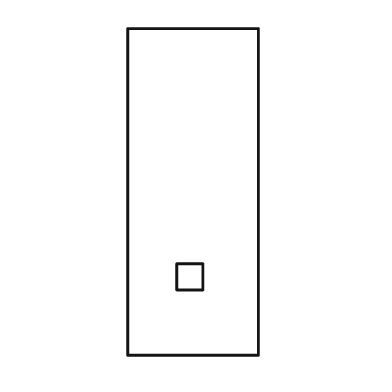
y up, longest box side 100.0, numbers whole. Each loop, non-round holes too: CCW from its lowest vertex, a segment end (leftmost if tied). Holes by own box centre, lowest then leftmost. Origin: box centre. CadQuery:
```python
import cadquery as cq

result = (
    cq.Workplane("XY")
    .moveTo(-20.0, -50.0)
    .lineTo(20.0, -50.0)
    .lineTo(20.0, 50.0)
    .lineTo(-20.0, 50.0)
    .close()
    .moveTo(-5.0, -30.0)
    .lineTo(3.0, -30.0)
    .lineTo(3.0, -22.0)
    .lineTo(-5.0, -22.0)
    .close()
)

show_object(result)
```